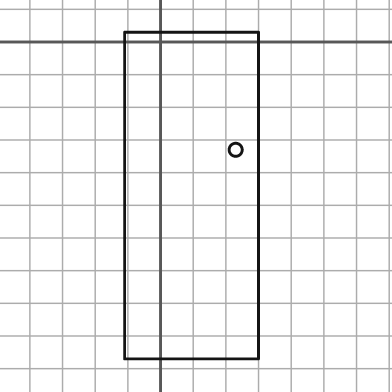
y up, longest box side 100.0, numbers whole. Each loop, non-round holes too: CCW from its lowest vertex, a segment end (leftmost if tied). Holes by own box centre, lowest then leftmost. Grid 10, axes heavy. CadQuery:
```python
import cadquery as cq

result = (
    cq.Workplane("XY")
    .moveTo(-11.0, -97.0)
    .lineTo(30.0, -97.0)
    .lineTo(30.0, 3.0)
    .lineTo(-11.0, 3.0)
    .close()
    .moveTo(23.0, -33.0)
    .circle(2.0)
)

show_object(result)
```